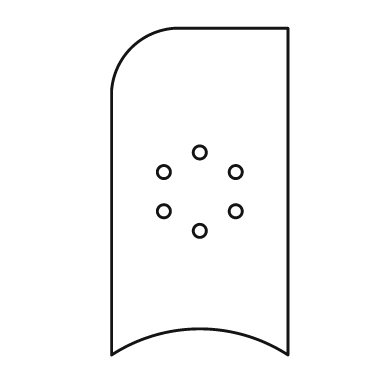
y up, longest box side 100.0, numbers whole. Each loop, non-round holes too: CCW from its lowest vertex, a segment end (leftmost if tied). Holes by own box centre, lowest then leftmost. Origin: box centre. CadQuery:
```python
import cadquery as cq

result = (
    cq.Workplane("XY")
    .moveTo(-27.0, -50.0)
    .threePointArc((0.0, -42.0), (27.0, -50.0))
    .lineTo(27.0, 50.0)
    .lineTo(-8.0, 50.0)
    .threePointArc((-21.0, 44.0), (-27.0, 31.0))
    .close()
    .moveTo(0.0, -12.0)
    .circle(2.0)
    .moveTo(-11.0, -6.0)
    .circle(2.0)
    .moveTo(11.0, -6.0)
    .circle(2.0)
    .moveTo(-11.0, 6.0)
    .circle(2.0)
    .moveTo(11.0, 6.0)
    .circle(2.0)
    .moveTo(0.0, 12.0)
    .circle(2.0)
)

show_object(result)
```